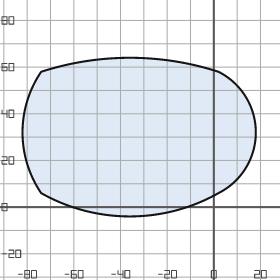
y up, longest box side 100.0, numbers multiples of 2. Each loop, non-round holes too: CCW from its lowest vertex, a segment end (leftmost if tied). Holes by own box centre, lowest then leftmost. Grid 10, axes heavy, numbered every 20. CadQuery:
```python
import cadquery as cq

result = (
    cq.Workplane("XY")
    .moveTo(-74.0, 6.0)
    .threePointArc((-36.0, -4.0), (2.0, 6.0))
    .threePointArc((18.0, 32.0), (2.0, 58.0))
    .threePointArc((-36.0, 64.0), (-74.0, 58.0))
    .threePointArc((-82.0, 32.0), (-74.0, 6.0))
    .close()
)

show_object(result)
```